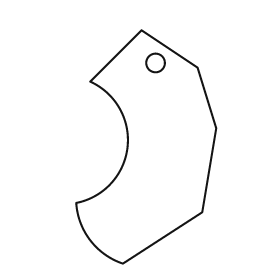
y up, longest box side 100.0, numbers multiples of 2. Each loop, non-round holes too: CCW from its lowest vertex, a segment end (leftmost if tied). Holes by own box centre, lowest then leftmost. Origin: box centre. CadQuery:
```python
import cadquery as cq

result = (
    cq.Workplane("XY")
    .moveTo(-10.0, -50.0)
    .lineTo(24.0, -28.0)
    .lineTo(30.0, 8.0)
    .lineTo(22.0, 34.0)
    .lineTo(-2.0, 50.0)
    .lineTo(-24.0, 28.0)
    .threePointArc((-8.0, 0.0), (-30.0, -24.0))
    .threePointArc((-24.0, -40.0), (-10.0, -50.0))
    .close()
    .moveTo(4.0, 36.0)
    .circle(4.0)
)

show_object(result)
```